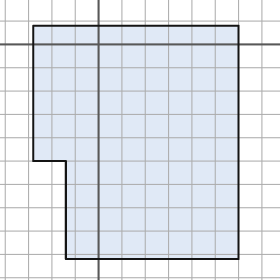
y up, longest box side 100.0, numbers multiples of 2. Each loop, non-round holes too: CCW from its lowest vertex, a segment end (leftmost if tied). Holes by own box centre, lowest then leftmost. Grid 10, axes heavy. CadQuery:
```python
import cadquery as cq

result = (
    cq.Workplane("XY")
    .moveTo(-14.0, -92.0)
    .lineTo(60.0, -92.0)
    .lineTo(60.0, 8.0)
    .lineTo(-28.0, 8.0)
    .lineTo(-28.0, -50.0)
    .lineTo(-14.0, -50.0)
    .close()
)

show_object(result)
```